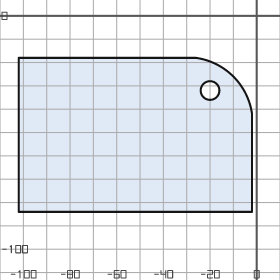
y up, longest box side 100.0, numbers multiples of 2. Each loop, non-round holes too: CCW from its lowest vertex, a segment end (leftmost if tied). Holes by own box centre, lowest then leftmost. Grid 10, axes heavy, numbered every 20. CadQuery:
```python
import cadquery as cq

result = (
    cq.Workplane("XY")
    .moveTo(-102.0, -84.0)
    .lineTo(-2.0, -84.0)
    .lineTo(-2.0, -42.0)
    .threePointArc((-10.0, -26.0), (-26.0, -18.0))
    .lineTo(-102.0, -18.0)
    .close()
    .moveTo(-20.0, -32.0)
    .circle(4.0)
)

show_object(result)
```